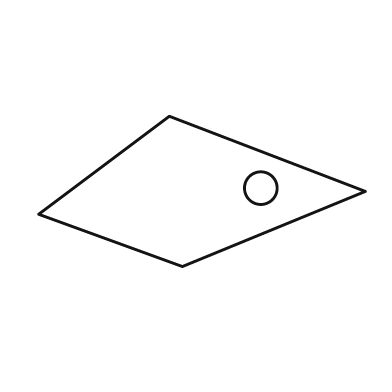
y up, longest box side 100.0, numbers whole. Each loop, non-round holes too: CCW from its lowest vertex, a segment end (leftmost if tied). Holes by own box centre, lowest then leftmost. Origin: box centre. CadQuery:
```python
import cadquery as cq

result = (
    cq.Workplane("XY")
    .moveTo(-6.0, -23.0)
    .lineTo(50.0, 0.0)
    .lineTo(-10.0, 23.0)
    .lineTo(-50.0, -7.0)
    .close()
    .moveTo(18.0, 1.0)
    .circle(5.0)
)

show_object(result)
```